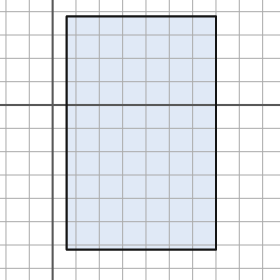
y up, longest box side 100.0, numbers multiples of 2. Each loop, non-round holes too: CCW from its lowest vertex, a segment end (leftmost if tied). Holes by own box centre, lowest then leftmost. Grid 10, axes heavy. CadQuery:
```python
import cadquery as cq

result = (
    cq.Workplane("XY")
    .moveTo(6.0, -62.0)
    .lineTo(70.0, -62.0)
    .lineTo(70.0, 38.0)
    .lineTo(6.0, 38.0)
    .close()
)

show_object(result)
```